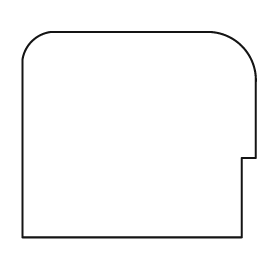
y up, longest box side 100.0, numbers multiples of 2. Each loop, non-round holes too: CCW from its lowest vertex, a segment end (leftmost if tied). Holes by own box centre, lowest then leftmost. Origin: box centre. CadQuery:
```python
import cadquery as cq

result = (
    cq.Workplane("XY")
    .moveTo(-50.0, -44.0)
    .lineTo(44.0, -44.0)
    .lineTo(44.0, -10.0)
    .lineTo(50.0, -10.0)
    .lineTo(50.0, 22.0)
    .threePointArc((44.0, 38.0), (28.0, 44.0))
    .lineTo(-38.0, 44.0)
    .threePointArc((-46.0, 40.0), (-50.0, 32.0))
    .close()
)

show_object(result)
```